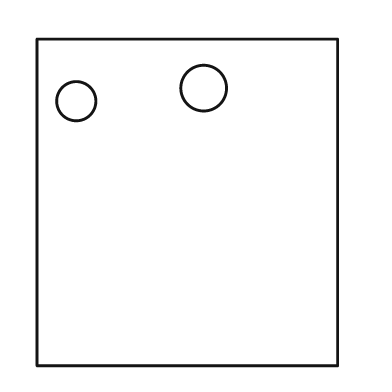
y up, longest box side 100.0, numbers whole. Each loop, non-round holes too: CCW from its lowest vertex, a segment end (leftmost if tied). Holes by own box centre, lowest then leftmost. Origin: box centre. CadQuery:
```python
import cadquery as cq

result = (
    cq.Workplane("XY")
    .moveTo(-46.0, -50.0)
    .lineTo(46.0, -50.0)
    .lineTo(46.0, 50.0)
    .lineTo(-46.0, 50.0)
    .close()
    .moveTo(-34.0, 31.0)
    .circle(6.0)
    .moveTo(5.0, 35.0)
    .circle(7.0)
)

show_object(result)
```